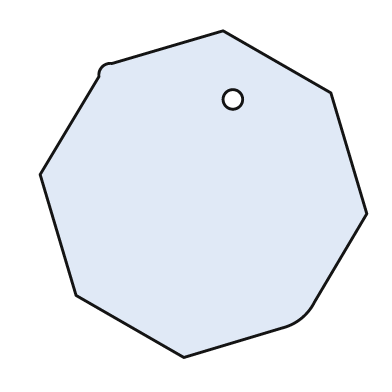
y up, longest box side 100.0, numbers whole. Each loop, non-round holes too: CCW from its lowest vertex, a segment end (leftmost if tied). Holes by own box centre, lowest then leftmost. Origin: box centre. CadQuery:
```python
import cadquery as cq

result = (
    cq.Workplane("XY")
    .moveTo(-6.0, -50.0)
    .lineTo(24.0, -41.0)
    .threePointArc((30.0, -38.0), (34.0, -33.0))
    .lineTo(50.0, -6.0)
    .lineTo(39.0, 31.0)
    .lineTo(6.0, 50.0)
    .lineTo(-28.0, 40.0)
    .threePointArc((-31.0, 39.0), (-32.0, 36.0))
    .lineTo(-50.0, 6.0)
    .lineTo(-39.0, -31.0)
    .close()
    .moveTo(9.0, 29.0)
    .circle(3.0)
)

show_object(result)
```